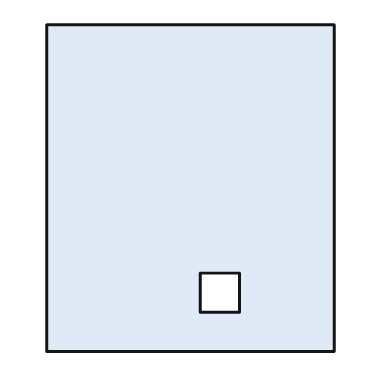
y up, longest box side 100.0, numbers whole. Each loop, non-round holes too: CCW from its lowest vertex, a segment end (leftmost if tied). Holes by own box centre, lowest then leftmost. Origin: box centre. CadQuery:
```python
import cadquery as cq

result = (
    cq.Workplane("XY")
    .moveTo(-44.0, -50.0)
    .lineTo(44.0, -50.0)
    .lineTo(44.0, 50.0)
    .lineTo(-44.0, 50.0)
    .close()
    .moveTo(3.0, -38.0)
    .lineTo(15.0, -38.0)
    .lineTo(15.0, -26.0)
    .lineTo(3.0, -26.0)
    .close()
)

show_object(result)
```